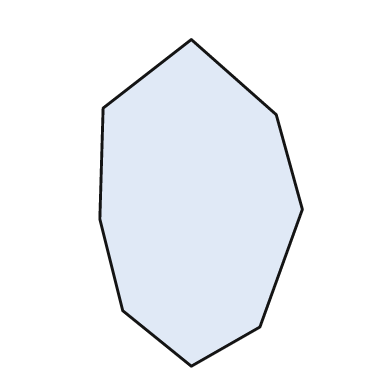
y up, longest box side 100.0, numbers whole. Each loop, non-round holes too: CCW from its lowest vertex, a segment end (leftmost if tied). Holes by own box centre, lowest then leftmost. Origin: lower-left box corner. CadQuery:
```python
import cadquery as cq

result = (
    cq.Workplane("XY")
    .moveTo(28.0, 0.0)
    .lineTo(49.0, 12.0)
    .lineTo(62.0, 48.0)
    .lineTo(54.0, 77.0)
    .lineTo(28.0, 100.0)
    .lineTo(1.0, 79.0)
    .lineTo(0.0, 45.0)
    .lineTo(7.0, 17.0)
    .close()
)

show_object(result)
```